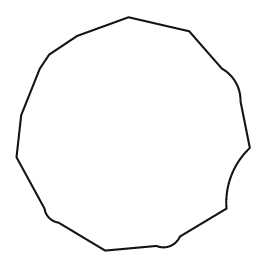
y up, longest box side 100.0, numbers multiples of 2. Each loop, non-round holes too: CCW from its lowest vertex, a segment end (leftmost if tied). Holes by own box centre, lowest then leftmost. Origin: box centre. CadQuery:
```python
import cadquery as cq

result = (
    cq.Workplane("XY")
    .moveTo(-12.0, -50.0)
    .lineTo(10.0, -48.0)
    .threePointArc((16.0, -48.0), (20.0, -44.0))
    .lineTo(40.0, -32.0)
    .threePointArc((42.0, -18.0), (50.0, -6.0))
    .lineTo(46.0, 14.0)
    .threePointArc((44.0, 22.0), (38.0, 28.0))
    .lineTo(24.0, 44.0)
    .lineTo(-2.0, 50.0)
    .lineTo(-24.0, 42.0)
    .lineTo(-36.0, 34.0)
    .lineTo(-40.0, 28.0)
    .lineTo(-48.0, 8.0)
    .lineTo(-50.0, -10.0)
    .lineTo(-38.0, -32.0)
    .threePointArc((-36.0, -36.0), (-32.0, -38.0))
    .close()
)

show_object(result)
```